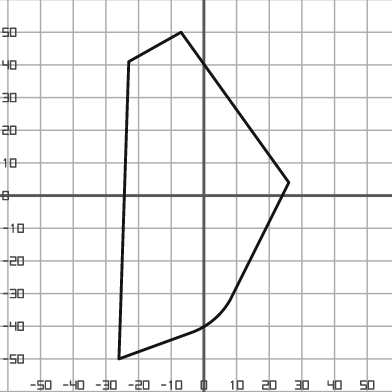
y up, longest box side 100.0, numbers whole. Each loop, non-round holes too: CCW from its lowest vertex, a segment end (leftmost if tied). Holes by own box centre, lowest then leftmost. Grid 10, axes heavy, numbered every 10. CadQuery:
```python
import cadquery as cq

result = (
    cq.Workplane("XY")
    .moveTo(-26.0, -50.0)
    .lineTo(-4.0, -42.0)
    .threePointArc((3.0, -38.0), (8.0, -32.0))
    .lineTo(26.0, 4.0)
    .lineTo(-7.0, 50.0)
    .lineTo(-23.0, 41.0)
    .close()
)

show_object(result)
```